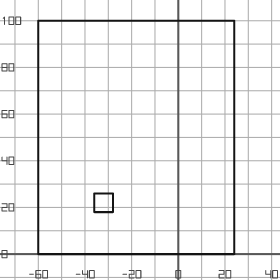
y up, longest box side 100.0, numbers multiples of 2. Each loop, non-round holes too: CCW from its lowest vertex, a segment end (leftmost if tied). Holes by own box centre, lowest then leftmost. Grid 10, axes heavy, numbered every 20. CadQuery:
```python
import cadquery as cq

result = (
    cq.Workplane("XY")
    .moveTo(-60.0, 0.0)
    .lineTo(24.0, 0.0)
    .lineTo(24.0, 100.0)
    .lineTo(-60.0, 100.0)
    .close()
    .moveTo(-36.0, 18.0)
    .lineTo(-28.0, 18.0)
    .lineTo(-28.0, 26.0)
    .lineTo(-36.0, 26.0)
    .close()
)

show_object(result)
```